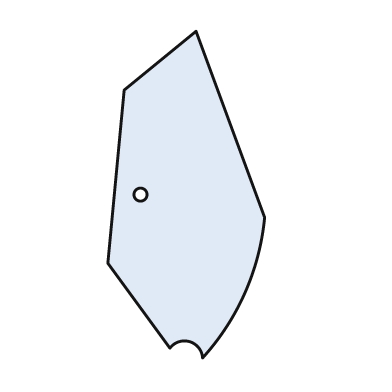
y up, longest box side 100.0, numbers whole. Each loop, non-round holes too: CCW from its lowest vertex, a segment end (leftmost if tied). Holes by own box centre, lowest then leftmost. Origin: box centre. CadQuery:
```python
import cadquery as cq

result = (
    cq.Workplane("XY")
    .moveTo(5.0, -50.0)
    .threePointArc((18.0, -30.0), (24.0, -7.0))
    .lineTo(3.0, 50.0)
    .lineTo(-19.0, 32.0)
    .lineTo(-24.0, -21.0)
    .lineTo(-5.0, -47.0)
    .threePointArc((1.0, -45.0), (5.0, -50.0))
    .close()
    .moveTo(-14.0, 0.0)
    .circle(2.0)
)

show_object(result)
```